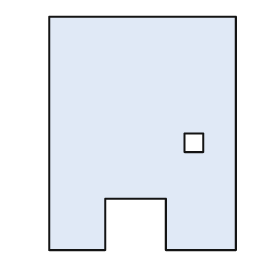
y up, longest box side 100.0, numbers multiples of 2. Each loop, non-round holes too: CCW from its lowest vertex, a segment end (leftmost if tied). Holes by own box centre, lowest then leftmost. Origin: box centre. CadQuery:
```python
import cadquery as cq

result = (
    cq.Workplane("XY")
    .moveTo(-40.0, -50.0)
    .lineTo(-16.0, -50.0)
    .lineTo(-16.0, -28.0)
    .lineTo(10.0, -28.0)
    .lineTo(10.0, -50.0)
    .lineTo(40.0, -50.0)
    .lineTo(40.0, 50.0)
    .lineTo(-40.0, 50.0)
    .close()
    .moveTo(18.0, -8.0)
    .lineTo(26.0, -8.0)
    .lineTo(26.0, 0.0)
    .lineTo(18.0, 0.0)
    .close()
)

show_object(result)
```